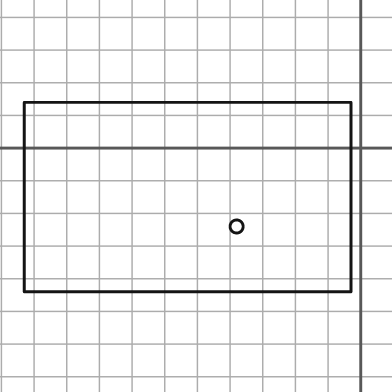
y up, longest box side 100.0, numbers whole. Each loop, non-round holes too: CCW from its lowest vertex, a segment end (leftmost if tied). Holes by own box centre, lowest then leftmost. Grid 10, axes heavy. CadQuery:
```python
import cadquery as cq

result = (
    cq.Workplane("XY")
    .moveTo(-103.0, -44.0)
    .lineTo(-3.0, -44.0)
    .lineTo(-3.0, 14.0)
    .lineTo(-103.0, 14.0)
    .close()
    .moveTo(-38.0, -24.0)
    .circle(2.0)
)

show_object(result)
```